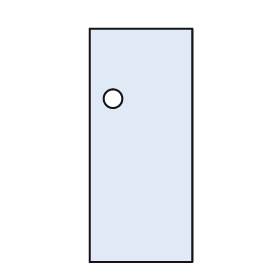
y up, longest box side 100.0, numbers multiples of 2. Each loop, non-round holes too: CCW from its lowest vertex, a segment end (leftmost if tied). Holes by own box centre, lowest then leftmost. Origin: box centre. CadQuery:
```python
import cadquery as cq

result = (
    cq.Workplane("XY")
    .moveTo(-22.0, -50.0)
    .lineTo(22.0, -50.0)
    .lineTo(22.0, 50.0)
    .lineTo(-22.0, 50.0)
    .close()
    .moveTo(-12.0, 20.0)
    .circle(4.0)
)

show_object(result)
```